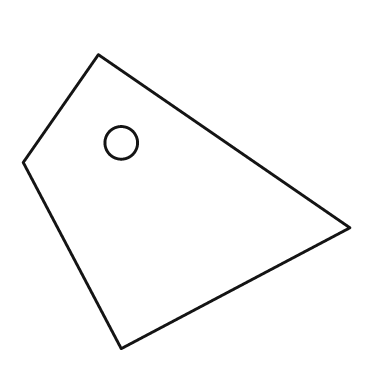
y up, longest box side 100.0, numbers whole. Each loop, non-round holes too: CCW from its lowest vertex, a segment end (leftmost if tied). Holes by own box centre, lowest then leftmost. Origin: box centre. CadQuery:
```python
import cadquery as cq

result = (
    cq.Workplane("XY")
    .moveTo(-20.0, -45.0)
    .lineTo(50.0, -8.0)
    .lineTo(-27.0, 45.0)
    .lineTo(-50.0, 12.0)
    .close()
    .moveTo(-20.0, 18.0)
    .circle(5.0)
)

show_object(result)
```